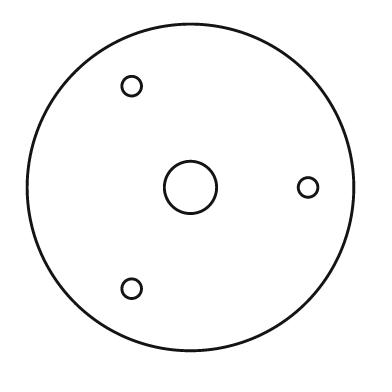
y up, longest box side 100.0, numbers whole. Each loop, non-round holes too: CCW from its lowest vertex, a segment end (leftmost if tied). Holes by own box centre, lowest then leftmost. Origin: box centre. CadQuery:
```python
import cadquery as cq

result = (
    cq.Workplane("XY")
    .moveTo(0.0, 0.0)
    .circle(50.0)
    .moveTo(-18.0, -31.0)
    .circle(3.0)
    .moveTo(0.0, 0.0)
    .circle(8.0)
    .moveTo(36.0, 0.0)
    .circle(3.0)
    .moveTo(-18.0, 31.0)
    .circle(3.0)
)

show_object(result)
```